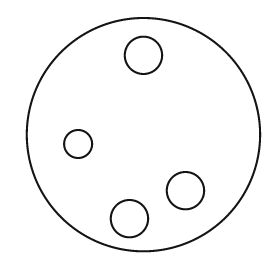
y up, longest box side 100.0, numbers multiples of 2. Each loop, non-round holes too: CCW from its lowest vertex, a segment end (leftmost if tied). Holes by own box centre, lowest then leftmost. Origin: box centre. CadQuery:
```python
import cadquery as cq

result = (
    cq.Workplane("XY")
    .moveTo(0.0, 0.0)
    .circle(50.0)
    .moveTo(-6.0, -36.0)
    .circle(8.0)
    .moveTo(18.0, -24.0)
    .circle(8.0)
    .moveTo(-28.0, -4.0)
    .circle(6.0)
    .moveTo(0.0, 34.0)
    .circle(8.0)
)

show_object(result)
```